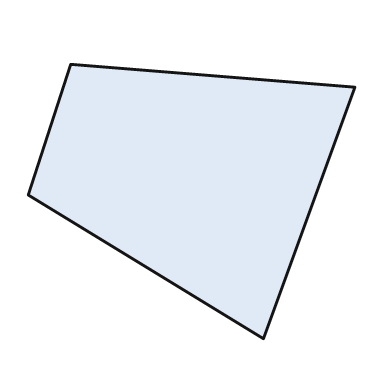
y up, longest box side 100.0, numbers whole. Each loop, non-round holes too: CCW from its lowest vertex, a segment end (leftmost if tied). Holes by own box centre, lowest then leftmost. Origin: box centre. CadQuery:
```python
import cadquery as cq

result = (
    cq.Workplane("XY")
    .moveTo(22.0, -42.0)
    .lineTo(50.0, 35.0)
    .lineTo(-37.0, 42.0)
    .lineTo(-50.0, 2.0)
    .close()
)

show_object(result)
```